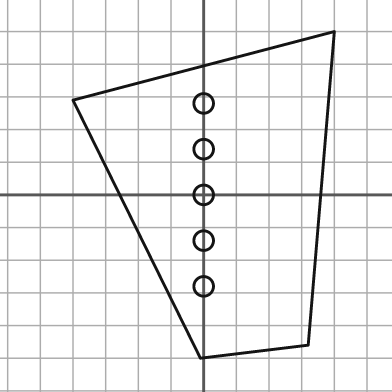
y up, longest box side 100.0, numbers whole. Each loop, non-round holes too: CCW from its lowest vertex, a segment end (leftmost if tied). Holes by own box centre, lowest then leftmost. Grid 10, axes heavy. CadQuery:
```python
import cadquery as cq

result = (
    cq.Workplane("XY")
    .moveTo(-1.0, -50.0)
    .lineTo(32.0, -46.0)
    .lineTo(40.0, 50.0)
    .lineTo(-40.0, 29.0)
    .close()
    .moveTo(0.0, -28.0)
    .circle(3.0)
    .moveTo(0.0, -14.0)
    .circle(3.0)
    .moveTo(0.0, 0.0)
    .circle(3.0)
    .moveTo(0.0, 14.0)
    .circle(3.0)
    .moveTo(0.0, 28.0)
    .circle(3.0)
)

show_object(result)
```